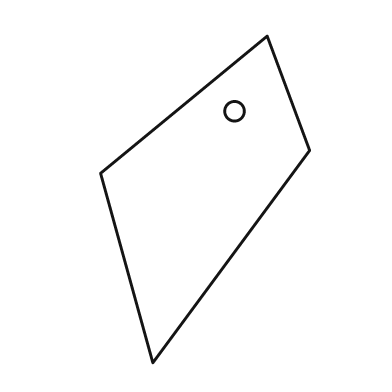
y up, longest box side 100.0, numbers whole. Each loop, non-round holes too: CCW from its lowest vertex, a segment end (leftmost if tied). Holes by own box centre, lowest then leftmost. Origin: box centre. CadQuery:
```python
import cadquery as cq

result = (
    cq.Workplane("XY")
    .moveTo(-16.0, -50.0)
    .lineTo(32.0, 15.0)
    .lineTo(19.0, 50.0)
    .lineTo(-32.0, 8.0)
    .close()
    .moveTo(9.0, 27.0)
    .circle(3.0)
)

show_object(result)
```